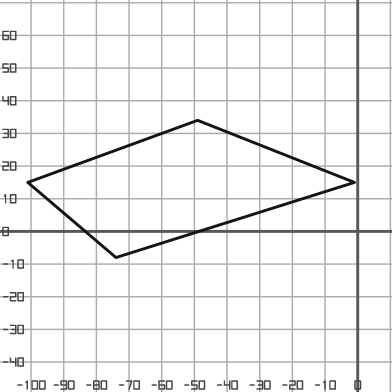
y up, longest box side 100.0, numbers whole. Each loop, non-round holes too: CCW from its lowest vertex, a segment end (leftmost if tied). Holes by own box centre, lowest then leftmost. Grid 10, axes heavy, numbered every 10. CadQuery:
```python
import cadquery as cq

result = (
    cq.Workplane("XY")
    .moveTo(-74.0, -8.0)
    .lineTo(-1.0, 15.0)
    .lineTo(-49.0, 34.0)
    .lineTo(-101.0, 15.0)
    .close()
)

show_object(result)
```